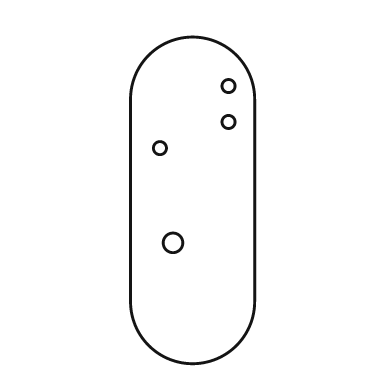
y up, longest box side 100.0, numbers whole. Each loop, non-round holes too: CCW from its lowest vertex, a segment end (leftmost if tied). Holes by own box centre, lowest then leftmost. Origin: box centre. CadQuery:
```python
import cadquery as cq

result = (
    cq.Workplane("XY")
    .moveTo(-19.0, -31.0)
    .threePointArc((0.0, -50.0), (19.0, -31.0))
    .lineTo(19.0, 31.0)
    .threePointArc((0.0, 50.0), (-19.0, 31.0))
    .close()
    .moveTo(-6.0, -13.0)
    .circle(3.0)
    .moveTo(-10.0, 16.0)
    .circle(2.0)
    .moveTo(11.0, 24.0)
    .circle(2.0)
    .moveTo(11.0, 35.0)
    .circle(2.0)
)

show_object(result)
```